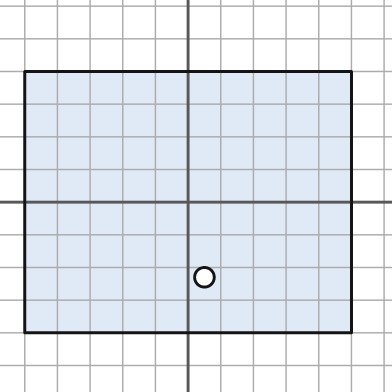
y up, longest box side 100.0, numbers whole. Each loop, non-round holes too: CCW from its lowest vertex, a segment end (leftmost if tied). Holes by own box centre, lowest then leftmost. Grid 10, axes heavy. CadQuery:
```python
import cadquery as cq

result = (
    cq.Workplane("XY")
    .moveTo(-50.0, -40.0)
    .lineTo(50.0, -40.0)
    .lineTo(50.0, 40.0)
    .lineTo(-50.0, 40.0)
    .close()
    .moveTo(5.0, -23.0)
    .circle(3.0)
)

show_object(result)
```